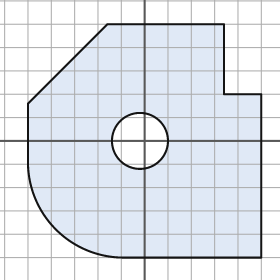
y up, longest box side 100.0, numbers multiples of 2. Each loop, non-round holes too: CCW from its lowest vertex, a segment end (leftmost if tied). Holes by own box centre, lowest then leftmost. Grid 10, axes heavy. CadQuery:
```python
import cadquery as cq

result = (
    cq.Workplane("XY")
    .moveTo(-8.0, -50.0)
    .lineTo(50.0, -50.0)
    .lineTo(50.0, 20.0)
    .lineTo(34.0, 20.0)
    .lineTo(34.0, 50.0)
    .lineTo(-16.0, 50.0)
    .lineTo(-50.0, 16.0)
    .lineTo(-50.0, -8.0)
    .threePointArc((-38.0, -38.0), (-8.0, -50.0))
    .close()
    .moveTo(-2.0, 0.0)
    .circle(12.0)
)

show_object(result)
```